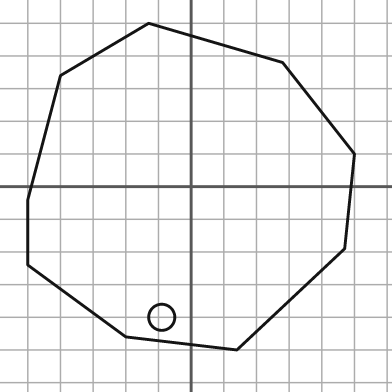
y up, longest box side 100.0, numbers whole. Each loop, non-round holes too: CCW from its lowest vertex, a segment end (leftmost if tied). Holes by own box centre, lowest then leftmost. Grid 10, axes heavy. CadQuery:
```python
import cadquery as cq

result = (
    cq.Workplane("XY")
    .moveTo(14.0, -50.0)
    .lineTo(47.0, -19.0)
    .lineTo(50.0, 10.0)
    .lineTo(28.0, 38.0)
    .lineTo(-13.0, 50.0)
    .lineTo(-40.0, 34.0)
    .lineTo(-50.0, -4.0)
    .lineTo(-50.0, -24.0)
    .lineTo(-20.0, -46.0)
    .close()
    .moveTo(-9.0, -40.0)
    .circle(4.0)
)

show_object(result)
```